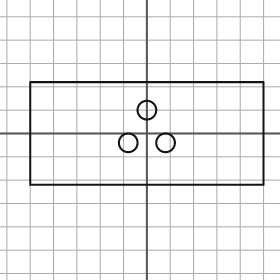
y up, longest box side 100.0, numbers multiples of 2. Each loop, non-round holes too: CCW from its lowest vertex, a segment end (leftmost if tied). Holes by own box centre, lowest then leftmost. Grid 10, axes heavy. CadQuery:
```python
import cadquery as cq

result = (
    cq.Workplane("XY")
    .moveTo(-50.0, -22.0)
    .lineTo(50.0, -22.0)
    .lineTo(50.0, 22.0)
    .lineTo(-50.0, 22.0)
    .close()
    .moveTo(-8.0, -4.0)
    .circle(4.0)
    .moveTo(8.0, -4.0)
    .circle(4.0)
    .moveTo(0.0, 10.0)
    .circle(4.0)
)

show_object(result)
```